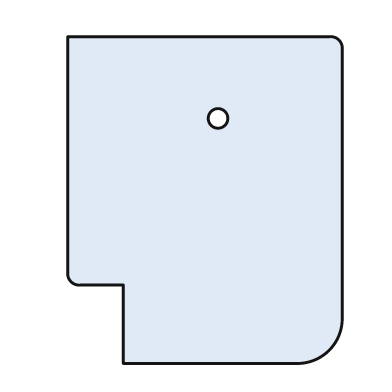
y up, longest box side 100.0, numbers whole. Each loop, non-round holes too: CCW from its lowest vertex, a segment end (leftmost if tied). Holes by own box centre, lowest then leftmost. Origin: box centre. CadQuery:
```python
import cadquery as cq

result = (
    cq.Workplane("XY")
    .moveTo(-25.0, -50.0)
    .lineTo(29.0, -50.0)
    .threePointArc((38.0, -46.0), (42.0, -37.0))
    .lineTo(42.0, 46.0)
    .threePointArc((41.0, 49.0), (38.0, 50.0))
    .lineTo(-42.0, 50.0)
    .lineTo(-42.0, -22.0)
    .threePointArc((-41.0, -25.0), (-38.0, -26.0))
    .lineTo(-25.0, -26.0)
    .close()
    .moveTo(4.0, 25.0)
    .circle(3.0)
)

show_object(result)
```